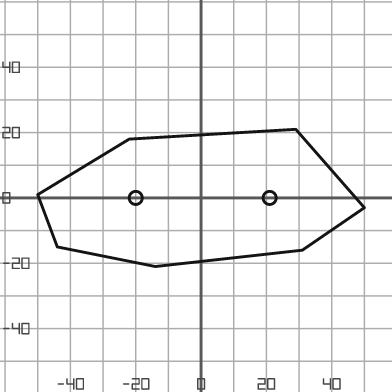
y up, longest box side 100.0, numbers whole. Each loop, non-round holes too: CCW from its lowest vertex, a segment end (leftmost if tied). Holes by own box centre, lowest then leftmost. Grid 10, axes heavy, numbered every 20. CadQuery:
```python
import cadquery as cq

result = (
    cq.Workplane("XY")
    .moveTo(-14.0, -21.0)
    .lineTo(31.0, -16.0)
    .lineTo(50.0, -3.0)
    .lineTo(29.0, 21.0)
    .lineTo(-22.0, 18.0)
    .lineTo(-50.0, 1.0)
    .lineTo(-44.0, -15.0)
    .close()
    .moveTo(-20.0, 0.0)
    .circle(2.0)
    .moveTo(21.0, 0.0)
    .circle(2.0)
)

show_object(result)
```